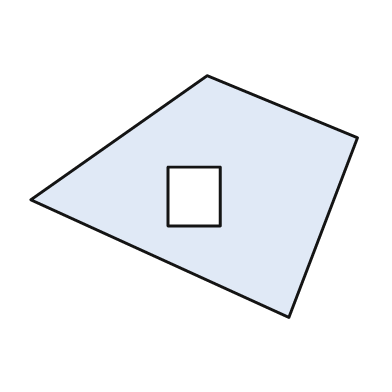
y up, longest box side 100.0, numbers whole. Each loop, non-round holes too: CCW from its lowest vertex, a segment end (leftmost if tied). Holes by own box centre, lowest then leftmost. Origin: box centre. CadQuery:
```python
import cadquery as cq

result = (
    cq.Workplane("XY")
    .moveTo(29.0, -37.0)
    .lineTo(50.0, 18.0)
    .lineTo(4.0, 37.0)
    .lineTo(-50.0, -1.0)
    .close()
    .moveTo(-8.0, -9.0)
    .lineTo(8.0, -9.0)
    .lineTo(8.0, 9.0)
    .lineTo(-8.0, 9.0)
    .close()
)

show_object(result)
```